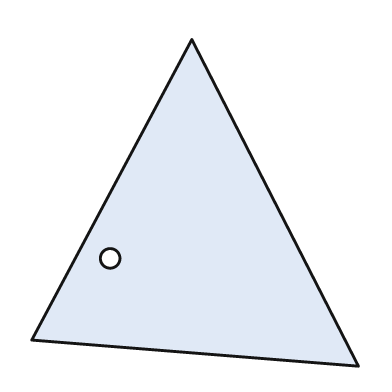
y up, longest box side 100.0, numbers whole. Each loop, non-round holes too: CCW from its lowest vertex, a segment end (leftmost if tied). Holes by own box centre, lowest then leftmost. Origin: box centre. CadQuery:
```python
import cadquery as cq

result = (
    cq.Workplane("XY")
    .moveTo(50.0, -50.0)
    .lineTo(-1.0, 50.0)
    .lineTo(-50.0, -42.0)
    .close()
    .moveTo(-26.0, -17.0)
    .circle(3.0)
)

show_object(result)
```